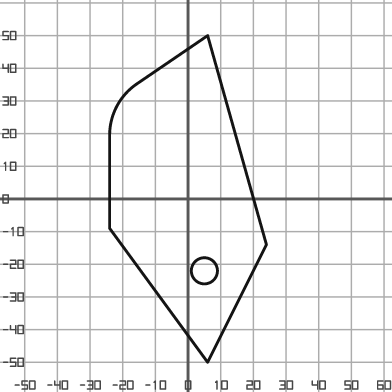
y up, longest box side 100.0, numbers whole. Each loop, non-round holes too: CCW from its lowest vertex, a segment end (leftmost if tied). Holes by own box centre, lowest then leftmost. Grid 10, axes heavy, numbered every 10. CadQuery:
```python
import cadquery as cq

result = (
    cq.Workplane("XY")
    .moveTo(6.0, -50.0)
    .lineTo(24.0, -14.0)
    .lineTo(6.0, 50.0)
    .lineTo(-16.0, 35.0)
    .threePointArc((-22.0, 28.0), (-24.0, 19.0))
    .lineTo(-24.0, -9.0)
    .close()
    .moveTo(5.0, -22.0)
    .circle(4.0)
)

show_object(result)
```